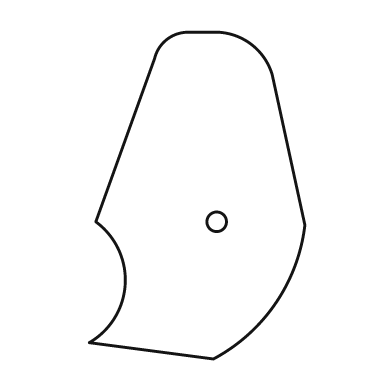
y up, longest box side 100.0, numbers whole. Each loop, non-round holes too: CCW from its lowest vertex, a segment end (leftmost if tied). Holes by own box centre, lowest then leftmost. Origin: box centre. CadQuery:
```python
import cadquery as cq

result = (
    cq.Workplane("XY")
    .moveTo(5.0, -50.0)
    .threePointArc((24.0, -33.0), (33.0, -9.0))
    .lineTo(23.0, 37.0)
    .threePointArc((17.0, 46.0), (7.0, 50.0))
    .lineTo(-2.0, 50.0)
    .threePointArc((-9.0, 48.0), (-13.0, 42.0))
    .lineTo(-31.0, -8.0)
    .threePointArc((-22.0, -27.0), (-33.0, -45.0))
    .close()
    .moveTo(6.0, -8.0)
    .circle(3.0)
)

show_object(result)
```